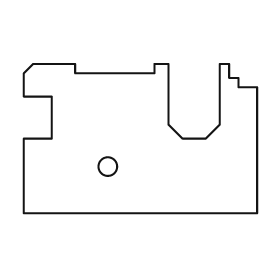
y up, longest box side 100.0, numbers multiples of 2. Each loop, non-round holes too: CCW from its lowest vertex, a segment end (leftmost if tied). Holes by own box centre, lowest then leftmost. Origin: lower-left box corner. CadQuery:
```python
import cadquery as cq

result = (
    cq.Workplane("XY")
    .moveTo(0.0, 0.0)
    .lineTo(100.0, 0.0)
    .lineTo(100.0, 54.0)
    .lineTo(92.0, 54.0)
    .lineTo(92.0, 58.0)
    .lineTo(88.0, 58.0)
    .lineTo(88.0, 64.0)
    .lineTo(84.0, 64.0)
    .lineTo(84.0, 38.0)
    .lineTo(78.0, 32.0)
    .lineTo(68.0, 32.0)
    .lineTo(62.0, 38.0)
    .lineTo(62.0, 64.0)
    .lineTo(56.0, 64.0)
    .lineTo(56.0, 60.0)
    .lineTo(22.0, 60.0)
    .lineTo(22.0, 64.0)
    .lineTo(4.0, 64.0)
    .lineTo(0.0, 60.0)
    .lineTo(0.0, 50.0)
    .lineTo(12.0, 50.0)
    .lineTo(12.0, 32.0)
    .lineTo(0.0, 32.0)
    .close()
    .moveTo(36.0, 20.0)
    .circle(4.0)
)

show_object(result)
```